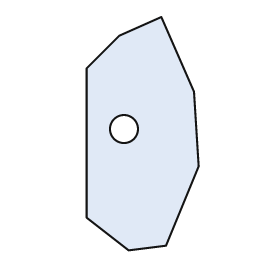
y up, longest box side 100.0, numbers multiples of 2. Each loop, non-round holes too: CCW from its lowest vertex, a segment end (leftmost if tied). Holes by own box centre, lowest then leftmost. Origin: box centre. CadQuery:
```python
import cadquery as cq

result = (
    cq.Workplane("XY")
    .moveTo(-6.0, -50.0)
    .lineTo(10.0, -48.0)
    .lineTo(24.0, -14.0)
    .lineTo(22.0, 18.0)
    .lineTo(8.0, 50.0)
    .lineTo(-10.0, 42.0)
    .lineTo(-24.0, 28.0)
    .lineTo(-24.0, -36.0)
    .close()
    .moveTo(-8.0, 2.0)
    .circle(6.0)
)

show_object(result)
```